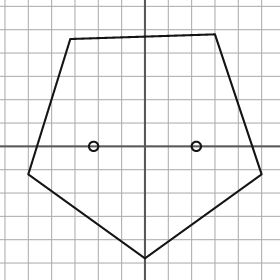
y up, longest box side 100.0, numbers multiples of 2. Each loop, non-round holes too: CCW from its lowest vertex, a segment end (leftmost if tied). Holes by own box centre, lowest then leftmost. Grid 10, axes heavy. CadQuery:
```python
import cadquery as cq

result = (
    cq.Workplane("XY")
    .moveTo(0.0, -48.0)
    .lineTo(50.0, -12.0)
    .lineTo(30.0, 48.0)
    .lineTo(-32.0, 46.0)
    .lineTo(-50.0, -12.0)
    .close()
    .moveTo(-22.0, 0.0)
    .circle(2.0)
    .moveTo(22.0, 0.0)
    .circle(2.0)
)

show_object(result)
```